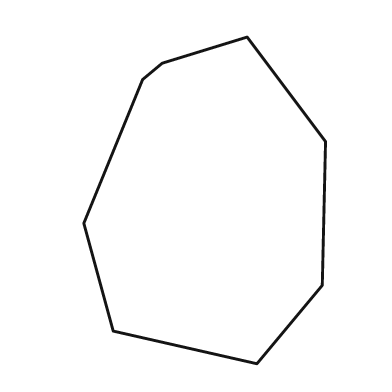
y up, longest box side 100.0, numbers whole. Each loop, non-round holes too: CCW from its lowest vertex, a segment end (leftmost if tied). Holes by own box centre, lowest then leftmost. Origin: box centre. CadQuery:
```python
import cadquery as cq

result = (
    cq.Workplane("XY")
    .moveTo(16.0, -50.0)
    .lineTo(36.0, -26.0)
    .lineTo(37.0, 18.0)
    .lineTo(13.0, 50.0)
    .lineTo(-13.0, 42.0)
    .lineTo(-19.0, 37.0)
    .lineTo(-37.0, -7.0)
    .lineTo(-28.0, -40.0)
    .close()
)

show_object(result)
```